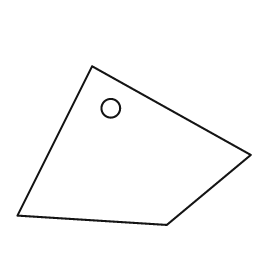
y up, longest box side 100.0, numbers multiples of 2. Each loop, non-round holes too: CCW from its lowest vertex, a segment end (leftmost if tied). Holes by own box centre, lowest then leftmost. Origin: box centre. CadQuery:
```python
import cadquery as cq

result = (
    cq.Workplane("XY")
    .moveTo(14.0, -34.0)
    .lineTo(50.0, -4.0)
    .lineTo(-18.0, 34.0)
    .lineTo(-50.0, -30.0)
    .close()
    .moveTo(-10.0, 16.0)
    .circle(4.0)
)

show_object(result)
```